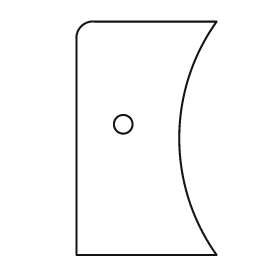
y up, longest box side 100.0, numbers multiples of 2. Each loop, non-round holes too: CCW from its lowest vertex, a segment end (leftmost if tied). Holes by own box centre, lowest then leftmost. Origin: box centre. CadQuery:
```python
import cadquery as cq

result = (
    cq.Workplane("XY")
    .moveTo(-30.0, -50.0)
    .lineTo(30.0, -50.0)
    .threePointArc((14.0, 0.0), (30.0, 50.0))
    .lineTo(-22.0, 50.0)
    .threePointArc((-28.0, 48.0), (-30.0, 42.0))
    .close()
    .moveTo(-10.0, 6.0)
    .circle(4.0)
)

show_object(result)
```